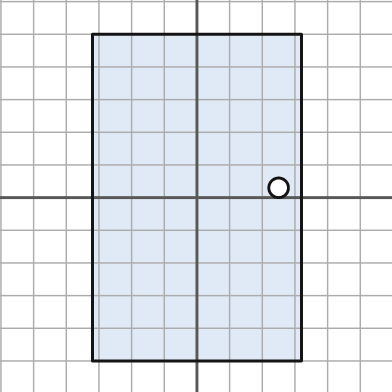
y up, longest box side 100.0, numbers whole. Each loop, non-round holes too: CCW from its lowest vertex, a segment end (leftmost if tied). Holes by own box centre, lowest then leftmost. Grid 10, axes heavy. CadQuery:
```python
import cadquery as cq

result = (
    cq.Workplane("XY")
    .moveTo(-32.0, -50.0)
    .lineTo(32.0, -50.0)
    .lineTo(32.0, 50.0)
    .lineTo(-32.0, 50.0)
    .close()
    .moveTo(25.0, 3.0)
    .circle(3.0)
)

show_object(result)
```